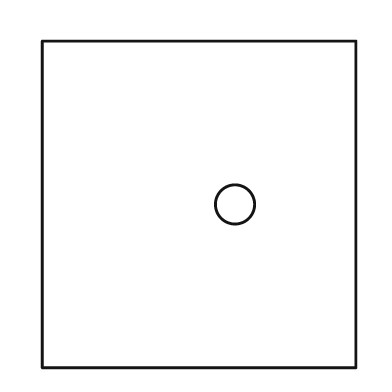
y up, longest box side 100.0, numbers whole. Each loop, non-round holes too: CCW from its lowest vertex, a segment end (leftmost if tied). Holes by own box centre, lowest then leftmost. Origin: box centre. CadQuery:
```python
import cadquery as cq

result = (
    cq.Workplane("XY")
    .moveTo(-48.0, -50.0)
    .lineTo(48.0, -50.0)
    .lineTo(48.0, 50.0)
    .lineTo(-48.0, 50.0)
    .close()
    .moveTo(11.0, 0.0)
    .circle(6.0)
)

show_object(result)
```